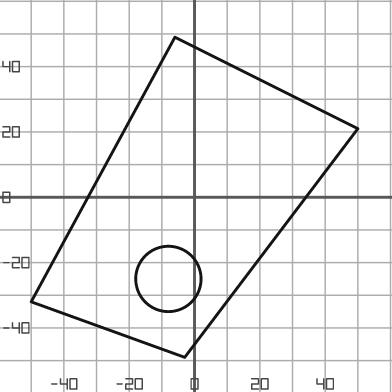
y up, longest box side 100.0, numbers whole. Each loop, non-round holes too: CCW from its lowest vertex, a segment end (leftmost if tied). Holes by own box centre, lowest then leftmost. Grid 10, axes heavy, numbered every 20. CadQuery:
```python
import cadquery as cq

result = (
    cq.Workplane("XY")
    .moveTo(-3.0, -49.0)
    .lineTo(50.0, 21.0)
    .lineTo(-6.0, 49.0)
    .lineTo(-50.0, -32.0)
    .close()
    .moveTo(-8.0, -25.0)
    .circle(10.0)
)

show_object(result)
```